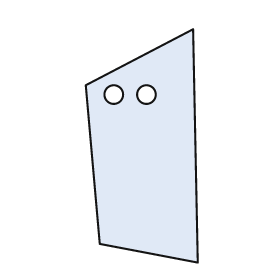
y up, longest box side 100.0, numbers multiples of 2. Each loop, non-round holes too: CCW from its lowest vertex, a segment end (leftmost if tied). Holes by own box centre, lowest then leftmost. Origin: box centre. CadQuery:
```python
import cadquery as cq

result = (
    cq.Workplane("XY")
    .moveTo(24.0, -50.0)
    .lineTo(22.0, 50.0)
    .lineTo(-24.0, 26.0)
    .lineTo(-18.0, -42.0)
    .close()
    .moveTo(-12.0, 22.0)
    .circle(4.0)
    .moveTo(2.0, 22.0)
    .circle(4.0)
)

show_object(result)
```